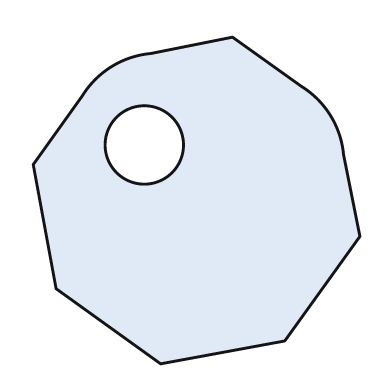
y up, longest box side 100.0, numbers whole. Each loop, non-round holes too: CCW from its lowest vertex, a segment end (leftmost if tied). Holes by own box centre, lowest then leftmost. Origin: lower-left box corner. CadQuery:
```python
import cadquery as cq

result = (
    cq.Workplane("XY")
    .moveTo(39.0, 0.0)
    .lineTo(77.0, 7.0)
    .lineTo(100.0, 39.0)
    .lineTo(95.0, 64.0)
    .threePointArc((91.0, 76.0), (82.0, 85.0))
    .lineTo(61.0, 100.0)
    .lineTo(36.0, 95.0)
    .threePointArc((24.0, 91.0), (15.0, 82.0))
    .lineTo(0.0, 61.0)
    .lineTo(7.0, 23.0)
    .close()
    .moveTo(34.0, 67.0)
    .circle(12.0)
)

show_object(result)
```